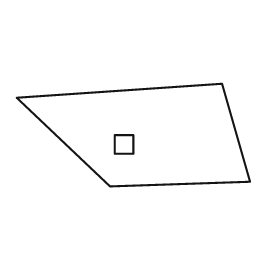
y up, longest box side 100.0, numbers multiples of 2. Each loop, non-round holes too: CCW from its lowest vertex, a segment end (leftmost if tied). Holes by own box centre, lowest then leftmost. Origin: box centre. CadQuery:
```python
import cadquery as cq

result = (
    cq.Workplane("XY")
    .moveTo(-10.0, -22.0)
    .lineTo(50.0, -20.0)
    .lineTo(38.0, 22.0)
    .lineTo(-50.0, 16.0)
    .close()
    .moveTo(-8.0, -8.0)
    .lineTo(0.0, -8.0)
    .lineTo(0.0, 0.0)
    .lineTo(-8.0, 0.0)
    .close()
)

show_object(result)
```